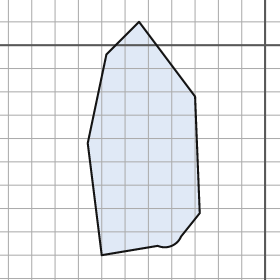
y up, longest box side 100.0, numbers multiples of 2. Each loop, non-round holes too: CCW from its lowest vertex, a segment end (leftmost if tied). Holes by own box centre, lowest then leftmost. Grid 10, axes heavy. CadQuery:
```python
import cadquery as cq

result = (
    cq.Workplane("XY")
    .moveTo(-70.0, -90.0)
    .lineTo(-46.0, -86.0)
    .threePointArc((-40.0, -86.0), (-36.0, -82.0))
    .lineTo(-28.0, -72.0)
    .lineTo(-30.0, -22.0)
    .lineTo(-54.0, 10.0)
    .lineTo(-68.0, -4.0)
    .lineTo(-76.0, -42.0)
    .close()
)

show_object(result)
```